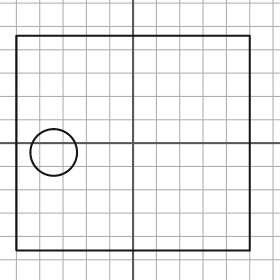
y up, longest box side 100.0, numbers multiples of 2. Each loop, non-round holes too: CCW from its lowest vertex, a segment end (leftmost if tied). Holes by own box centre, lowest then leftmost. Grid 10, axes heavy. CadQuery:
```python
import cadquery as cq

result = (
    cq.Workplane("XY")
    .moveTo(-50.0, -46.0)
    .lineTo(50.0, -46.0)
    .lineTo(50.0, 46.0)
    .lineTo(-50.0, 46.0)
    .close()
    .moveTo(-34.0, -4.0)
    .circle(10.0)
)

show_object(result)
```